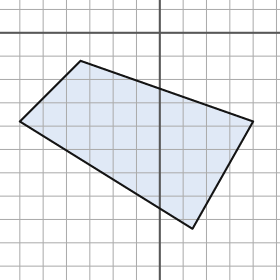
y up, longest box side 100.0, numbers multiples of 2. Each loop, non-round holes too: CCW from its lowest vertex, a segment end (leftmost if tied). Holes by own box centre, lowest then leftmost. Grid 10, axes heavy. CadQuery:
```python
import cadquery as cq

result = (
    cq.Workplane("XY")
    .moveTo(14.0, -84.0)
    .lineTo(40.0, -38.0)
    .lineTo(-34.0, -12.0)
    .lineTo(-60.0, -38.0)
    .close()
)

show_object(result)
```